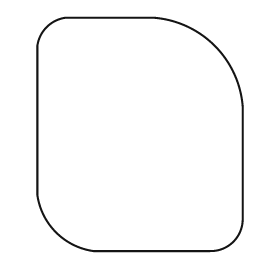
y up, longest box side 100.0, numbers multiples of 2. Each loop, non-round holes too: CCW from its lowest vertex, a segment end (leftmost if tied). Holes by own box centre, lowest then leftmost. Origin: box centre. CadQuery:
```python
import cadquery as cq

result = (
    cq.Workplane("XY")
    .moveTo(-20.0, -50.0)
    .lineTo(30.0, -50.0)
    .threePointArc((40.0, -46.0), (44.0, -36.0))
    .lineTo(44.0, 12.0)
    .threePointArc((32.0, 38.0), (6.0, 50.0))
    .lineTo(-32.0, 50.0)
    .threePointArc((-40.0, 46.0), (-44.0, 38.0))
    .lineTo(-44.0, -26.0)
    .threePointArc((-36.0, -42.0), (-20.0, -50.0))
    .close()
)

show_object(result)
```